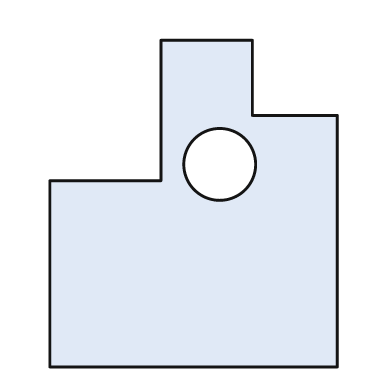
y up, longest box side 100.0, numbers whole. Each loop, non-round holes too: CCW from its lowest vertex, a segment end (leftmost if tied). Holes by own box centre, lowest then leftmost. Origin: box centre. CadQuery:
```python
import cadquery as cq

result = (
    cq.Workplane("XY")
    .moveTo(-44.0, -50.0)
    .lineTo(44.0, -50.0)
    .lineTo(44.0, 27.0)
    .lineTo(18.0, 27.0)
    .lineTo(18.0, 50.0)
    .lineTo(-10.0, 50.0)
    .lineTo(-10.0, 7.0)
    .lineTo(-44.0, 7.0)
    .close()
    .moveTo(8.0, 12.0)
    .circle(11.0)
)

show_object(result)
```